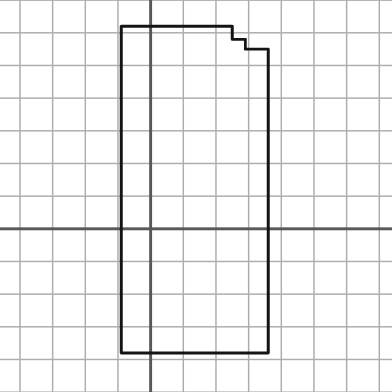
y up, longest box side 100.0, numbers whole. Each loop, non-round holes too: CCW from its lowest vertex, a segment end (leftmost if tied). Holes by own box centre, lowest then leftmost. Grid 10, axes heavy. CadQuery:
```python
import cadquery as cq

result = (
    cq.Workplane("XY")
    .moveTo(-9.0, -38.0)
    .lineTo(36.0, -38.0)
    .lineTo(36.0, 55.0)
    .lineTo(29.0, 55.0)
    .lineTo(29.0, 58.0)
    .lineTo(25.0, 58.0)
    .lineTo(25.0, 62.0)
    .lineTo(-9.0, 62.0)
    .close()
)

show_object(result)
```